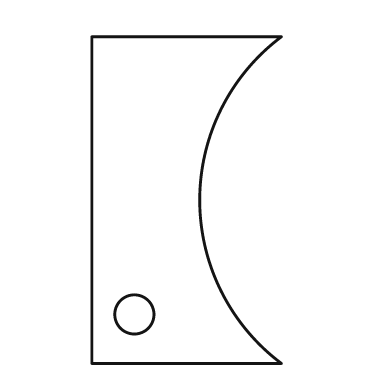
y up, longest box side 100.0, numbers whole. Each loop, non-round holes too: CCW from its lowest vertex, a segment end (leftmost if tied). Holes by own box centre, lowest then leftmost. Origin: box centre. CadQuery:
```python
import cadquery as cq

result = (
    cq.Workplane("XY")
    .moveTo(-29.0, -50.0)
    .lineTo(29.0, -50.0)
    .threePointArc((4.0, 0.0), (29.0, 50.0))
    .lineTo(-29.0, 50.0)
    .close()
    .moveTo(-16.0, -35.0)
    .circle(6.0)
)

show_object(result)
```